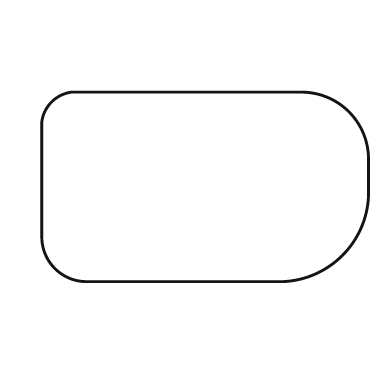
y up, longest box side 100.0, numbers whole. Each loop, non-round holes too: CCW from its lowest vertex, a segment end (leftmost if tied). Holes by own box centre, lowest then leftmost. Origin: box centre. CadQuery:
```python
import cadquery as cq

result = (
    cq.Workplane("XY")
    .moveTo(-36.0, -29.0)
    .lineTo(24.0, -29.0)
    .threePointArc((42.0, -21.0), (50.0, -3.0))
    .lineTo(50.0, 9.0)
    .threePointArc((44.0, 23.0), (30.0, 29.0))
    .lineTo(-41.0, 29.0)
    .threePointArc((-47.0, 26.0), (-50.0, 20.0))
    .lineTo(-50.0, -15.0)
    .threePointArc((-46.0, -25.0), (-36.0, -29.0))
    .close()
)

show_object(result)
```